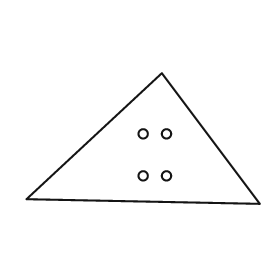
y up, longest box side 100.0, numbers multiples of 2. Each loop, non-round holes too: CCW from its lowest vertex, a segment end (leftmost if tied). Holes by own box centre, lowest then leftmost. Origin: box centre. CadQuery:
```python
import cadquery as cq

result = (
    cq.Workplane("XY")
    .moveTo(50.0, -28.0)
    .lineTo(8.0, 28.0)
    .lineTo(-50.0, -26.0)
    .close()
    .moveTo(0.0, -16.0)
    .circle(2.0)
    .moveTo(10.0, -16.0)
    .circle(2.0)
    .moveTo(0.0, 2.0)
    .circle(2.0)
    .moveTo(10.0, 2.0)
    .circle(2.0)
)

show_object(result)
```